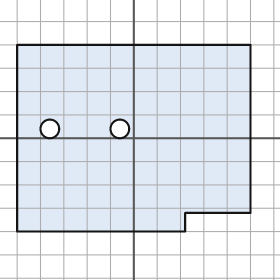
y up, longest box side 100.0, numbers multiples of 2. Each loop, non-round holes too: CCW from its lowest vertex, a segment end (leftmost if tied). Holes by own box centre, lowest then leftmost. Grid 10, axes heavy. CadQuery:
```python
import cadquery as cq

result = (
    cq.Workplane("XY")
    .moveTo(-50.0, -40.0)
    .lineTo(22.0, -40.0)
    .lineTo(22.0, -32.0)
    .lineTo(50.0, -32.0)
    .lineTo(50.0, 40.0)
    .lineTo(-50.0, 40.0)
    .close()
    .moveTo(-36.0, 4.0)
    .circle(4.0)
    .moveTo(-6.0, 4.0)
    .circle(4.0)
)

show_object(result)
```